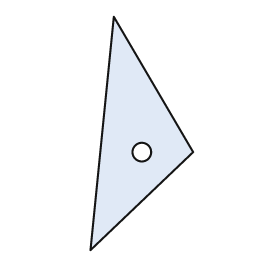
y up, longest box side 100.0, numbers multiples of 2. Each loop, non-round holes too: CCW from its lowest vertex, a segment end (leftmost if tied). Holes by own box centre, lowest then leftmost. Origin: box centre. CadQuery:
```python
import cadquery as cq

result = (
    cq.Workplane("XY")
    .moveTo(-22.0, -50.0)
    .lineTo(22.0, -8.0)
    .lineTo(-12.0, 50.0)
    .close()
    .moveTo(0.0, -8.0)
    .circle(4.0)
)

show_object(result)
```